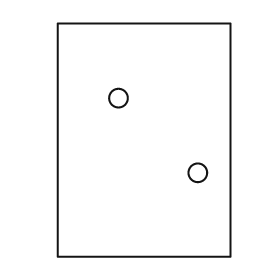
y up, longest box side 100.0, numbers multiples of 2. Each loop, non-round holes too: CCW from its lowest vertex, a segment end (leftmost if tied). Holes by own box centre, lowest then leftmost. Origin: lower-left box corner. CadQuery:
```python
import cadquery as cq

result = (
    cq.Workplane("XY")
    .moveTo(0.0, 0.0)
    .lineTo(74.0, 0.0)
    .lineTo(74.0, 100.0)
    .lineTo(0.0, 100.0)
    .close()
    .moveTo(60.0, 36.0)
    .circle(4.0)
    .moveTo(26.0, 68.0)
    .circle(4.0)
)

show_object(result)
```